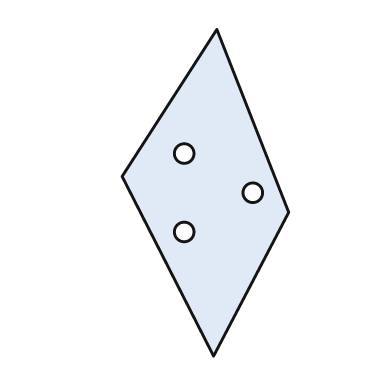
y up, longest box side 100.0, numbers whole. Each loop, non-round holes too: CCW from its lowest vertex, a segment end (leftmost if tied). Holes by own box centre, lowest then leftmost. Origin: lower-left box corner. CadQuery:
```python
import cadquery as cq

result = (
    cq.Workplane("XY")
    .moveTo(28.0, 0.0)
    .lineTo(51.0, 44.0)
    .lineTo(29.0, 100.0)
    .lineTo(0.0, 55.0)
    .close()
    .moveTo(19.0, 38.0)
    .circle(3.0)
    .moveTo(40.0, 50.0)
    .circle(3.0)
    .moveTo(19.0, 62.0)
    .circle(3.0)
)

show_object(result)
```